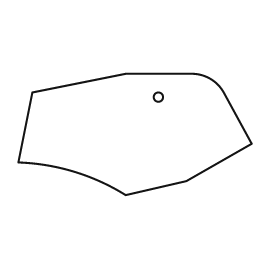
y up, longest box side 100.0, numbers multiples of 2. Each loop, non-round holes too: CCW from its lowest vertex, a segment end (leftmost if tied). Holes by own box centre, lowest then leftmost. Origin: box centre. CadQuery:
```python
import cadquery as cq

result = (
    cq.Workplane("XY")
    .moveTo(-4.0, -26.0)
    .lineTo(22.0, -20.0)
    .lineTo(50.0, -4.0)
    .lineTo(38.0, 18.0)
    .threePointArc((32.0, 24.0), (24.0, 26.0))
    .lineTo(-4.0, 26.0)
    .lineTo(-44.0, 18.0)
    .lineTo(-50.0, -12.0)
    .threePointArc((-26.0, -16.0), (-4.0, -26.0))
    .close()
    .moveTo(10.0, 16.0)
    .circle(2.0)
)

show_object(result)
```